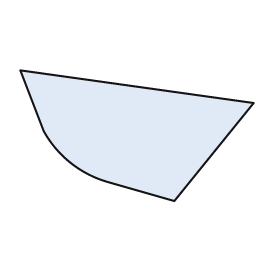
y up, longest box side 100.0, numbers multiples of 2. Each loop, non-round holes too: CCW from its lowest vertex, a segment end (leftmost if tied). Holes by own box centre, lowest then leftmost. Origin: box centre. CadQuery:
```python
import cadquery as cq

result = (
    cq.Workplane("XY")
    .moveTo(16.0, -28.0)
    .lineTo(50.0, 14.0)
    .lineTo(-50.0, 28.0)
    .lineTo(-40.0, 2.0)
    .threePointArc((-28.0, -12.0), (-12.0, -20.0))
    .close()
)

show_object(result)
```